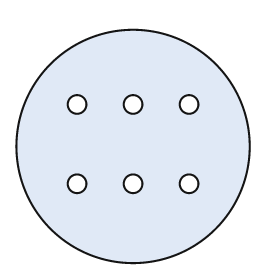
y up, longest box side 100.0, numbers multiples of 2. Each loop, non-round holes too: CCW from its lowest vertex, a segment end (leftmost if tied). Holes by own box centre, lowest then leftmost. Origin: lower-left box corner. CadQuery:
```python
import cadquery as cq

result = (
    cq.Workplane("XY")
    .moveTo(50.0, 50.0)
    .circle(50.0)
    .moveTo(26.0, 34.0)
    .circle(4.0)
    .moveTo(50.0, 34.0)
    .circle(4.0)
    .moveTo(74.0, 34.0)
    .circle(4.0)
    .moveTo(26.0, 68.0)
    .circle(4.0)
    .moveTo(50.0, 68.0)
    .circle(4.0)
    .moveTo(74.0, 68.0)
    .circle(4.0)
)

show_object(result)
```